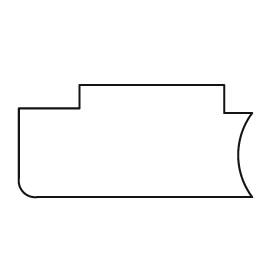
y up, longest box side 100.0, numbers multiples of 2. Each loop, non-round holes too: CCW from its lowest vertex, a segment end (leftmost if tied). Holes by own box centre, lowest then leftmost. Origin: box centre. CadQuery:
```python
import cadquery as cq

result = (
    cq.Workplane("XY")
    .moveTo(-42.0, -24.0)
    .lineTo(50.0, -24.0)
    .threePointArc((44.0, -6.0), (50.0, 12.0))
    .lineTo(38.0, 12.0)
    .lineTo(38.0, 24.0)
    .lineTo(-24.0, 24.0)
    .lineTo(-24.0, 14.0)
    .lineTo(-50.0, 14.0)
    .lineTo(-50.0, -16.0)
    .threePointArc((-48.0, -22.0), (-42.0, -24.0))
    .close()
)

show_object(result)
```